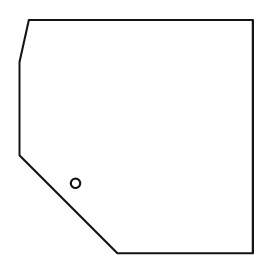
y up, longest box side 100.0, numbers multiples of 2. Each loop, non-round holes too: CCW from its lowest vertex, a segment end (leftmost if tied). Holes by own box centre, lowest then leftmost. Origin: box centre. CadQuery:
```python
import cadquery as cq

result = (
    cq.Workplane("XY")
    .moveTo(-8.0, -50.0)
    .lineTo(50.0, -50.0)
    .lineTo(50.0, 50.0)
    .lineTo(-46.0, 50.0)
    .lineTo(-50.0, 32.0)
    .lineTo(-50.0, -8.0)
    .close()
    .moveTo(-26.0, -20.0)
    .circle(2.0)
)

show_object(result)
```